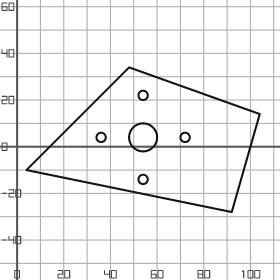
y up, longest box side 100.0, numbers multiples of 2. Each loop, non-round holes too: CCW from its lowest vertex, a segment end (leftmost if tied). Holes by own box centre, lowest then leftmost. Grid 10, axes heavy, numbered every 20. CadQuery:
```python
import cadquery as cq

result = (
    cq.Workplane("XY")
    .moveTo(92.0, -28.0)
    .lineTo(104.0, 14.0)
    .lineTo(48.0, 34.0)
    .lineTo(4.0, -10.0)
    .close()
    .moveTo(54.0, -14.0)
    .circle(2.0)
    .moveTo(36.0, 4.0)
    .circle(2.0)
    .moveTo(54.0, 4.0)
    .circle(6.0)
    .moveTo(72.0, 4.0)
    .circle(2.0)
    .moveTo(54.0, 22.0)
    .circle(2.0)
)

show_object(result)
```